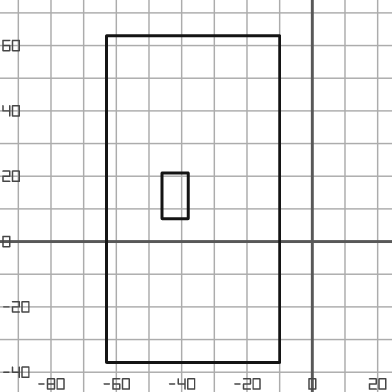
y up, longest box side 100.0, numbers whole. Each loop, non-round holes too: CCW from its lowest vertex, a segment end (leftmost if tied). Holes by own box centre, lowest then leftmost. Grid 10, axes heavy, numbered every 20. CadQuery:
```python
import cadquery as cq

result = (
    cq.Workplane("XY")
    .moveTo(-63.0, -37.0)
    .lineTo(-10.0, -37.0)
    .lineTo(-10.0, 63.0)
    .lineTo(-63.0, 63.0)
    .close()
    .moveTo(-46.0, 7.0)
    .lineTo(-38.0, 7.0)
    .lineTo(-38.0, 21.0)
    .lineTo(-46.0, 21.0)
    .close()
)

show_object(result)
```